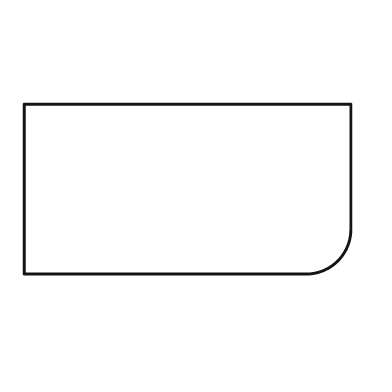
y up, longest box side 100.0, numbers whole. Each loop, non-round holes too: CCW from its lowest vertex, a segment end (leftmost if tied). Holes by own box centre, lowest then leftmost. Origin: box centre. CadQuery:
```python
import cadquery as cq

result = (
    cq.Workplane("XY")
    .moveTo(-50.0, -26.0)
    .lineTo(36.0, -26.0)
    .threePointArc((46.0, -22.0), (50.0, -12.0))
    .lineTo(50.0, 26.0)
    .lineTo(-50.0, 26.0)
    .close()
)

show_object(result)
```